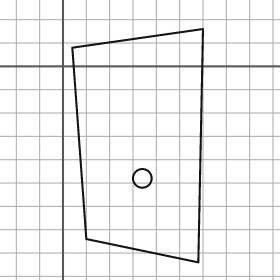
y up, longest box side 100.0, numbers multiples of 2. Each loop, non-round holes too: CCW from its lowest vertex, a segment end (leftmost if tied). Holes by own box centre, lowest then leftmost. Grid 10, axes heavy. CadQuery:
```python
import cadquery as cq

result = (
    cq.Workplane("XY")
    .moveTo(58.0, -84.0)
    .lineTo(60.0, 16.0)
    .lineTo(4.0, 8.0)
    .lineTo(10.0, -74.0)
    .close()
    .moveTo(34.0, -48.0)
    .circle(4.0)
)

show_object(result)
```